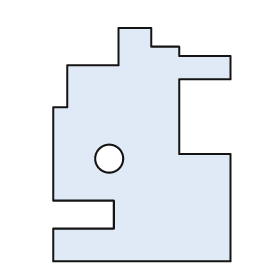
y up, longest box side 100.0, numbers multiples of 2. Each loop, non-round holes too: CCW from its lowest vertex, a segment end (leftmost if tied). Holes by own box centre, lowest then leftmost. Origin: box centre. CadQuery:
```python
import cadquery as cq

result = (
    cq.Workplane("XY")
    .moveTo(-38.0, -50.0)
    .lineTo(38.0, -50.0)
    .lineTo(38.0, -4.0)
    .lineTo(16.0, -4.0)
    .lineTo(16.0, 28.0)
    .lineTo(38.0, 28.0)
    .lineTo(38.0, 38.0)
    .lineTo(16.0, 38.0)
    .lineTo(16.0, 42.0)
    .lineTo(4.0, 42.0)
    .lineTo(4.0, 50.0)
    .lineTo(-10.0, 50.0)
    .lineTo(-10.0, 34.0)
    .lineTo(-32.0, 34.0)
    .lineTo(-32.0, 16.0)
    .lineTo(-38.0, 16.0)
    .lineTo(-38.0, -24.0)
    .lineTo(-12.0, -24.0)
    .lineTo(-12.0, -36.0)
    .lineTo(-38.0, -36.0)
    .close()
    .moveTo(-14.0, -6.0)
    .circle(6.0)
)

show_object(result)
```